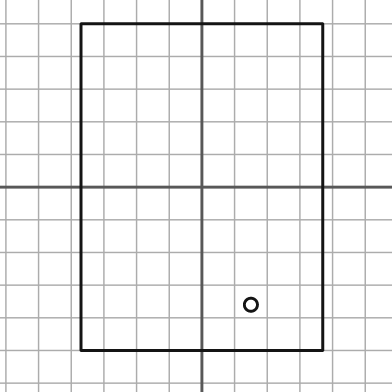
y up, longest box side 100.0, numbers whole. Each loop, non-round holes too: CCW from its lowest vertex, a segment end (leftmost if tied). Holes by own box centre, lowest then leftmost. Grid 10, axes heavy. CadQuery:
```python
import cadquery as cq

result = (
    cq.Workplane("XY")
    .moveTo(-37.0, -50.0)
    .lineTo(37.0, -50.0)
    .lineTo(37.0, 50.0)
    .lineTo(-37.0, 50.0)
    .close()
    .moveTo(15.0, -36.0)
    .circle(2.0)
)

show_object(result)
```